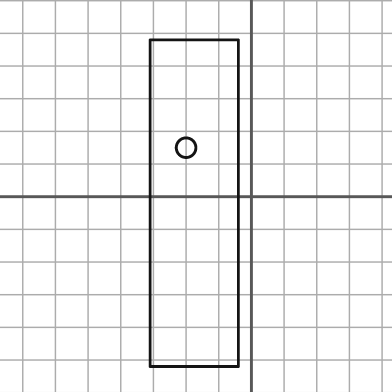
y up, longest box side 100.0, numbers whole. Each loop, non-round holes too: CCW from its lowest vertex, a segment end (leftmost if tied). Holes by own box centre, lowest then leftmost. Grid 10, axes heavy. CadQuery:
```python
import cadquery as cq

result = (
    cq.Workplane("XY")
    .moveTo(-31.0, -52.0)
    .lineTo(-4.0, -52.0)
    .lineTo(-4.0, 48.0)
    .lineTo(-31.0, 48.0)
    .close()
    .moveTo(-20.0, 15.0)
    .circle(3.0)
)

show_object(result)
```